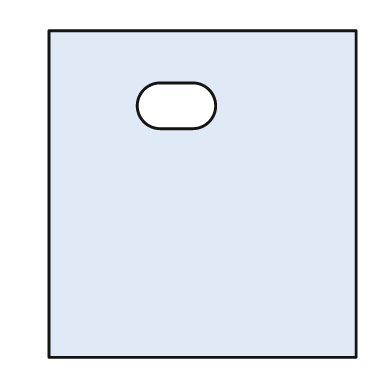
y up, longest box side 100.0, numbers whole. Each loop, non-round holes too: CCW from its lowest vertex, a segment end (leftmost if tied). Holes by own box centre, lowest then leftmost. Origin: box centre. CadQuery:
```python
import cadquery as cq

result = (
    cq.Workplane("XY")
    .moveTo(-47.0, -50.0)
    .lineTo(47.0, -50.0)
    .lineTo(47.0, 50.0)
    .lineTo(-47.0, 50.0)
    .close()
    .moveTo(-13.0, 20.0)
    .lineTo(-3.0, 20.0)
    .threePointArc((4.0, 27.0), (-3.0, 34.0))
    .lineTo(-13.0, 34.0)
    .threePointArc((-20.0, 27.0), (-13.0, 20.0))
    .close()
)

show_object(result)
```